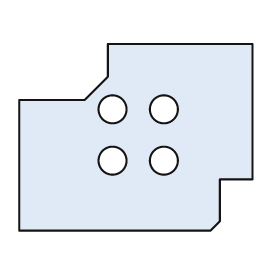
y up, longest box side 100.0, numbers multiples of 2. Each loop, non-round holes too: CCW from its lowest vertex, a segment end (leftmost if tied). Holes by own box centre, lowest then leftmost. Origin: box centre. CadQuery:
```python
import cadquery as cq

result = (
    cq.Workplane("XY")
    .moveTo(-50.0, -40.0)
    .lineTo(32.0, -40.0)
    .lineTo(36.0, -36.0)
    .lineTo(36.0, -18.0)
    .lineTo(50.0, -18.0)
    .lineTo(50.0, 40.0)
    .lineTo(-12.0, 40.0)
    .lineTo(-12.0, 26.0)
    .lineTo(-22.0, 16.0)
    .lineTo(-50.0, 16.0)
    .close()
    .moveTo(-10.0, -10.0)
    .circle(6.0)
    .moveTo(12.0, -10.0)
    .circle(6.0)
    .moveTo(-10.0, 12.0)
    .circle(6.0)
    .moveTo(12.0, 12.0)
    .circle(6.0)
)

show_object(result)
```